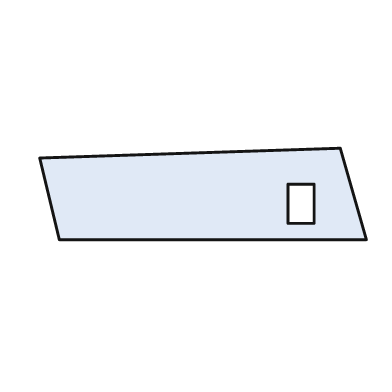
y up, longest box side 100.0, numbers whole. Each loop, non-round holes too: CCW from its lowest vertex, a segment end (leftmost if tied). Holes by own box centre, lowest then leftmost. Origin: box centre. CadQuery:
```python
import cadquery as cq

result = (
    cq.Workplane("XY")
    .moveTo(-44.0, -14.0)
    .lineTo(50.0, -14.0)
    .lineTo(42.0, 14.0)
    .lineTo(-50.0, 11.0)
    .close()
    .moveTo(26.0, -9.0)
    .lineTo(34.0, -9.0)
    .lineTo(34.0, 3.0)
    .lineTo(26.0, 3.0)
    .close()
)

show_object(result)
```